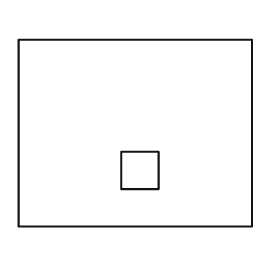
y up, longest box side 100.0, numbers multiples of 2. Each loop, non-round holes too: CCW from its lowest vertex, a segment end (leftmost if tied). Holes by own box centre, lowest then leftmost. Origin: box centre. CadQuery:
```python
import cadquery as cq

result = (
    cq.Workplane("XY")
    .moveTo(-50.0, -40.0)
    .lineTo(50.0, -40.0)
    .lineTo(50.0, 40.0)
    .lineTo(-50.0, 40.0)
    .close()
    .moveTo(-6.0, -24.0)
    .lineTo(10.0, -24.0)
    .lineTo(10.0, -8.0)
    .lineTo(-6.0, -8.0)
    .close()
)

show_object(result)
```